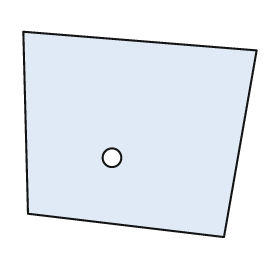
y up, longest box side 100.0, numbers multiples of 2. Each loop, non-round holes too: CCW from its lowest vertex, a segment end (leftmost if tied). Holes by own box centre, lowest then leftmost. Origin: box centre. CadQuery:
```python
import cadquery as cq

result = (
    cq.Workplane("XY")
    .moveTo(36.0, -44.0)
    .lineTo(50.0, 36.0)
    .lineTo(-50.0, 44.0)
    .lineTo(-48.0, -34.0)
    .close()
    .moveTo(-12.0, -10.0)
    .circle(4.0)
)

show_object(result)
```